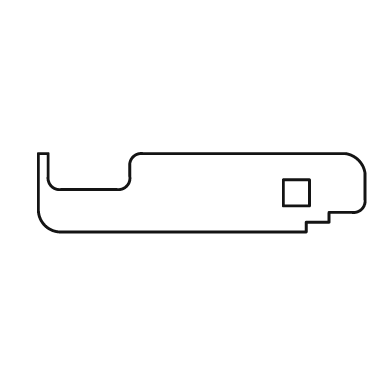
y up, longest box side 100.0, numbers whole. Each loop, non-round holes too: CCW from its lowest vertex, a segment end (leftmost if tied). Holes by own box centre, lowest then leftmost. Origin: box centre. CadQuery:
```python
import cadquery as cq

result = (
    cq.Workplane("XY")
    .moveTo(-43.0, -12.0)
    .lineTo(32.0, -12.0)
    .lineTo(32.0, -9.0)
    .lineTo(39.0, -9.0)
    .lineTo(39.0, -6.0)
    .lineTo(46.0, -6.0)
    .threePointArc((49.0, -5.0), (50.0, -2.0))
    .lineTo(50.0, 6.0)
    .threePointArc((48.0, 10.0), (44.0, 12.0))
    .lineTo(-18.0, 12.0)
    .threePointArc((-21.0, 11.0), (-22.0, 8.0))
    .lineTo(-22.0, 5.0)
    .threePointArc((-23.0, 2.0), (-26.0, 1.0))
    .lineTo(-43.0, 1.0)
    .threePointArc((-46.0, 2.0), (-47.0, 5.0))
    .lineTo(-47.0, 12.0)
    .lineTo(-50.0, 12.0)
    .lineTo(-50.0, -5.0)
    .threePointArc((-48.0, -10.0), (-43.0, -12.0))
    .close()
    .moveTo(25.0, -4.0)
    .lineTo(33.0, -4.0)
    .lineTo(33.0, 4.0)
    .lineTo(25.0, 4.0)
    .close()
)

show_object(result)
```